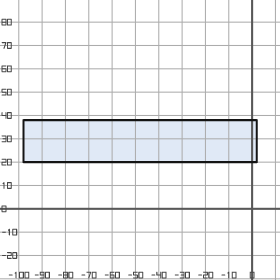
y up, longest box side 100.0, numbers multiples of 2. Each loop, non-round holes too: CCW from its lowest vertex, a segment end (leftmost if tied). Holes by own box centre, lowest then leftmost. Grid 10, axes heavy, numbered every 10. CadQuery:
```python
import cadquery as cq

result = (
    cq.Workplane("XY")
    .moveTo(-98.0, 20.0)
    .lineTo(2.0, 20.0)
    .lineTo(2.0, 38.0)
    .lineTo(-98.0, 38.0)
    .close()
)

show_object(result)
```